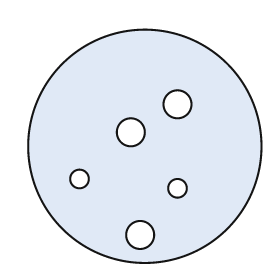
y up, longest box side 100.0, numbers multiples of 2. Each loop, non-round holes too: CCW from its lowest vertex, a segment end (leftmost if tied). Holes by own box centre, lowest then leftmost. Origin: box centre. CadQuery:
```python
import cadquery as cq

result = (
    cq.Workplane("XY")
    .moveTo(0.0, 0.0)
    .circle(50.0)
    .moveTo(-2.0, -38.0)
    .circle(6.0)
    .moveTo(14.0, -18.0)
    .circle(4.0)
    .moveTo(-28.0, -14.0)
    .circle(4.0)
    .moveTo(-6.0, 6.0)
    .circle(6.0)
    .moveTo(14.0, 18.0)
    .circle(6.0)
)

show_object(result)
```